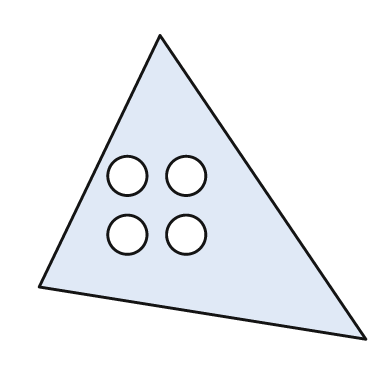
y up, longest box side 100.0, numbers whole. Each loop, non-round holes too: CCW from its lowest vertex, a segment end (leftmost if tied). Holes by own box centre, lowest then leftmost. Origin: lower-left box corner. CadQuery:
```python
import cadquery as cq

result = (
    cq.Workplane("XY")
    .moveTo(100.0, 0.0)
    .lineTo(37.0, 93.0)
    .lineTo(0.0, 16.0)
    .close()
    .moveTo(27.0, 32.0)
    .circle(6.0)
    .moveTo(45.0, 32.0)
    .circle(6.0)
    .moveTo(27.0, 50.0)
    .circle(6.0)
    .moveTo(45.0, 50.0)
    .circle(6.0)
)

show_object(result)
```